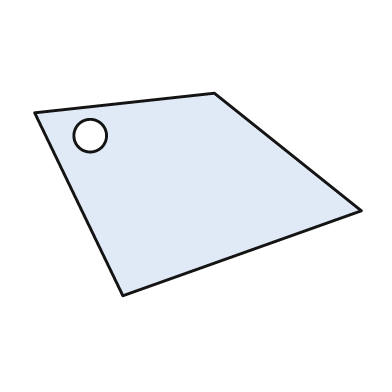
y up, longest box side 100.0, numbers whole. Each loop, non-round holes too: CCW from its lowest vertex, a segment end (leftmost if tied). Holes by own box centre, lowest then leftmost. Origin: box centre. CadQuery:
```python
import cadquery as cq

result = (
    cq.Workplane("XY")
    .moveTo(-23.0, -31.0)
    .lineTo(50.0, -5.0)
    .lineTo(5.0, 31.0)
    .lineTo(-50.0, 25.0)
    .close()
    .moveTo(-33.0, 18.0)
    .circle(5.0)
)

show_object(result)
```